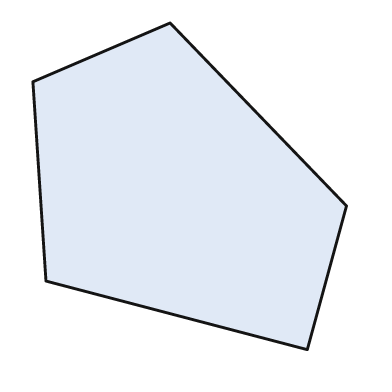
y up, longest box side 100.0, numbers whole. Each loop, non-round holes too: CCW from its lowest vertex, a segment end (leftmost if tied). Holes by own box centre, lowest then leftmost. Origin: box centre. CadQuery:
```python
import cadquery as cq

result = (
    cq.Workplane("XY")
    .moveTo(36.0, -50.0)
    .lineTo(48.0, -6.0)
    .lineTo(-6.0, 50.0)
    .lineTo(-48.0, 32.0)
    .lineTo(-44.0, -29.0)
    .close()
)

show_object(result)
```